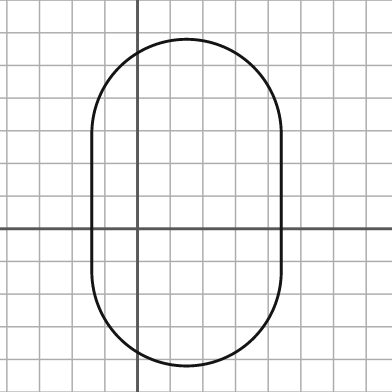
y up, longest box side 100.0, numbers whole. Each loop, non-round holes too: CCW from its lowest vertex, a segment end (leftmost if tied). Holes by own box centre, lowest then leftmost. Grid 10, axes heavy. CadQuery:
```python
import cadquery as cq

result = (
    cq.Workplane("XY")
    .moveTo(-14.0, -13.0)
    .threePointArc((15.0, -42.0), (44.0, -13.0))
    .lineTo(44.0, 29.0)
    .threePointArc((15.0, 58.0), (-14.0, 29.0))
    .close()
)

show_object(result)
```